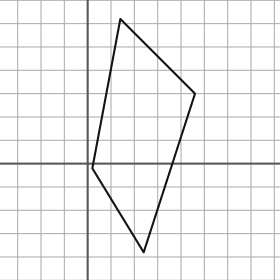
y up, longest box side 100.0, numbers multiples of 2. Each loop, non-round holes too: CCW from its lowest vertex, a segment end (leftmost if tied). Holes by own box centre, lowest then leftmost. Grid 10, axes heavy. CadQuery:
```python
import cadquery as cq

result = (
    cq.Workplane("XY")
    .moveTo(24.0, -38.0)
    .lineTo(46.0, 30.0)
    .lineTo(14.0, 62.0)
    .lineTo(2.0, -2.0)
    .close()
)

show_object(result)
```